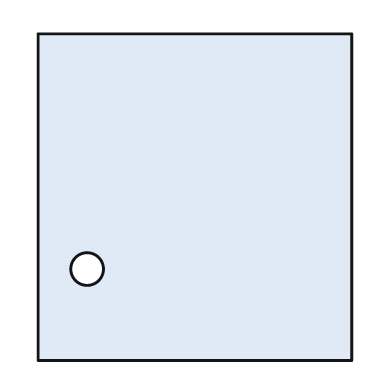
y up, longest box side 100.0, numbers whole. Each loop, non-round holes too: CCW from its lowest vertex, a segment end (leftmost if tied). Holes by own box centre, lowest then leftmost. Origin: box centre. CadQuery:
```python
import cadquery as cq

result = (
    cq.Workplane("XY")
    .moveTo(-48.0, -50.0)
    .lineTo(48.0, -50.0)
    .lineTo(48.0, 50.0)
    .lineTo(-48.0, 50.0)
    .close()
    .moveTo(-33.0, -22.0)
    .circle(5.0)
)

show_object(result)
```